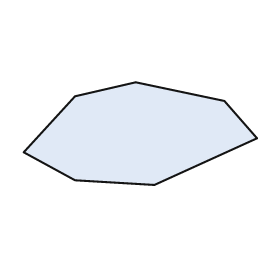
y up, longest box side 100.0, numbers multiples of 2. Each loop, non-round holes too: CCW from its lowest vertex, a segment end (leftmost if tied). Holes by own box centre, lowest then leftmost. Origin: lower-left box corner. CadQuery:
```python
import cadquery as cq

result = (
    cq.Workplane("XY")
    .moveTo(56.0, 0.0)
    .lineTo(100.0, 20.0)
    .lineTo(86.0, 36.0)
    .lineTo(48.0, 44.0)
    .lineTo(22.0, 38.0)
    .lineTo(0.0, 14.0)
    .lineTo(22.0, 2.0)
    .close()
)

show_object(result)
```